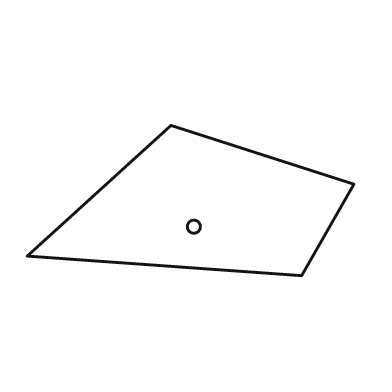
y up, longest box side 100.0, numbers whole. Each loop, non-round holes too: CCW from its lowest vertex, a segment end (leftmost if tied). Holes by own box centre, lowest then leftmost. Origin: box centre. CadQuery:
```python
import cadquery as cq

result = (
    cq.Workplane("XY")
    .moveTo(34.0, -23.0)
    .lineTo(50.0, 5.0)
    .lineTo(-6.0, 23.0)
    .lineTo(-50.0, -17.0)
    .close()
    .moveTo(1.0, -8.0)
    .circle(2.0)
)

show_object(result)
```